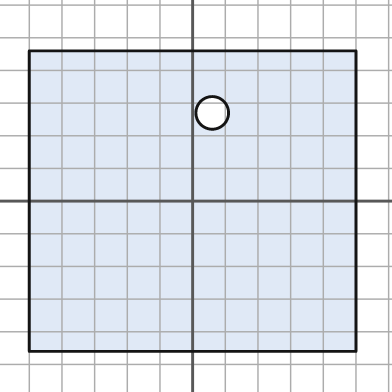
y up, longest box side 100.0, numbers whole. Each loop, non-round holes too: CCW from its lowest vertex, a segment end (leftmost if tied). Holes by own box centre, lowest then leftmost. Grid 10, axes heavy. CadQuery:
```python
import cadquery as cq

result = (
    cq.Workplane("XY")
    .moveTo(-50.0, -46.0)
    .lineTo(50.0, -46.0)
    .lineTo(50.0, 46.0)
    .lineTo(-50.0, 46.0)
    .close()
    .moveTo(6.0, 27.0)
    .circle(5.0)
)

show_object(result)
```